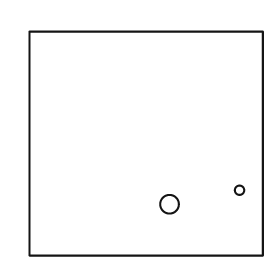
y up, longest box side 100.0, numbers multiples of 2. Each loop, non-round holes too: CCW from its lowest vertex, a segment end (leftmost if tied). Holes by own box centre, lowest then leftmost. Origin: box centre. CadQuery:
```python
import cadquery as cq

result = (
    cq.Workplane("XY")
    .moveTo(-50.0, -48.0)
    .lineTo(50.0, -48.0)
    .lineTo(50.0, 48.0)
    .lineTo(-50.0, 48.0)
    .close()
    .moveTo(10.0, -26.0)
    .circle(4.0)
    .moveTo(40.0, -20.0)
    .circle(2.0)
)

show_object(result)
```